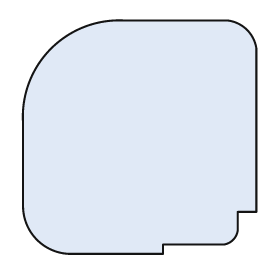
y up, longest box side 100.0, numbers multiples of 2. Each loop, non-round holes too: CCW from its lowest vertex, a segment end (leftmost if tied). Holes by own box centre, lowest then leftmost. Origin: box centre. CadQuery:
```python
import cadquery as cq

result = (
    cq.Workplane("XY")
    .moveTo(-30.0, -50.0)
    .lineTo(10.0, -50.0)
    .lineTo(10.0, -46.0)
    .lineTo(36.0, -46.0)
    .threePointArc((40.0, -44.0), (42.0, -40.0))
    .lineTo(42.0, -32.0)
    .lineTo(50.0, -32.0)
    .lineTo(50.0, 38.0)
    .threePointArc((46.0, 46.0), (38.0, 50.0))
    .lineTo(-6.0, 50.0)
    .threePointArc((-38.0, 38.0), (-50.0, 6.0))
    .lineTo(-50.0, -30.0)
    .threePointArc((-44.0, -44.0), (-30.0, -50.0))
    .close()
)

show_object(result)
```